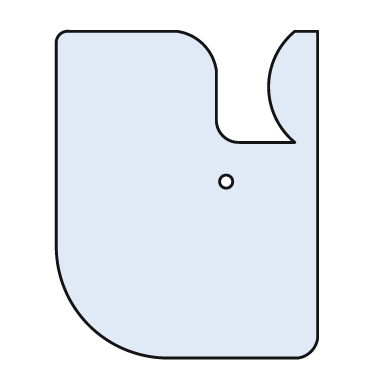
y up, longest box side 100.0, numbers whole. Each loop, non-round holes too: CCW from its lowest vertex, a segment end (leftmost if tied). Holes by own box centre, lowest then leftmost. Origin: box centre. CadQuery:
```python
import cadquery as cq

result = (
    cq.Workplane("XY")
    .moveTo(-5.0, -50.0)
    .lineTo(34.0, -50.0)
    .threePointArc((38.0, -48.0), (40.0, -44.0))
    .lineTo(40.0, 50.0)
    .lineTo(33.0, 50.0)
    .threePointArc((25.0, 33.0), (33.0, 16.0))
    .lineTo(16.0, 16.0)
    .threePointArc((11.0, 18.0), (9.0, 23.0))
    .lineTo(9.0, 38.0)
    .threePointArc((5.0, 46.0), (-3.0, 50.0))
    .lineTo(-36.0, 50.0)
    .threePointArc((-39.0, 49.0), (-40.0, 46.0))
    .lineTo(-40.0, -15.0)
    .threePointArc((-30.0, -40.0), (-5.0, -50.0))
    .close()
    .moveTo(12.0, 4.0)
    .circle(2.0)
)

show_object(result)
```